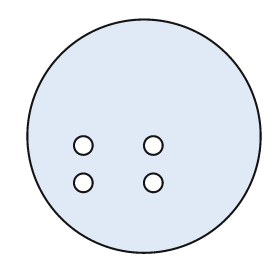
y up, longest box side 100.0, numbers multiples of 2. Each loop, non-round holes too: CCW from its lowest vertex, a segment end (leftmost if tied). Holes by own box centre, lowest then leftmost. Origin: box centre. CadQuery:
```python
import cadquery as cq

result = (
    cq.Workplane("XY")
    .moveTo(0.0, 0.0)
    .circle(50.0)
    .moveTo(-26.0, -20.0)
    .circle(4.0)
    .moveTo(4.0, -20.0)
    .circle(4.0)
    .moveTo(-26.0, -4.0)
    .circle(4.0)
    .moveTo(4.0, -4.0)
    .circle(4.0)
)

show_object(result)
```